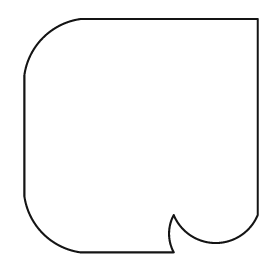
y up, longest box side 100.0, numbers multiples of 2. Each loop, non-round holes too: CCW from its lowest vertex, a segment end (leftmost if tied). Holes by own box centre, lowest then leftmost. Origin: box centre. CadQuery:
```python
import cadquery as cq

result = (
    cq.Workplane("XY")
    .moveTo(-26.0, -50.0)
    .lineTo(14.0, -50.0)
    .threePointArc((12.0, -42.0), (14.0, -34.0))
    .threePointArc((32.0, -46.0), (50.0, -34.0))
    .lineTo(50.0, 50.0)
    .lineTo(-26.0, 50.0)
    .threePointArc((-42.0, 42.0), (-50.0, 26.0))
    .lineTo(-50.0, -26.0)
    .threePointArc((-42.0, -42.0), (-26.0, -50.0))
    .close()
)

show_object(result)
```